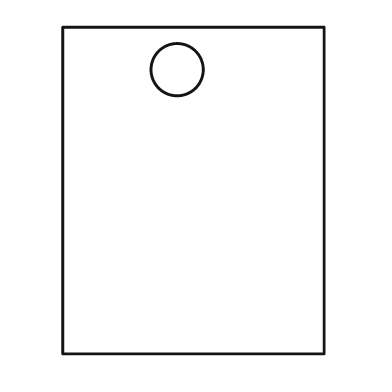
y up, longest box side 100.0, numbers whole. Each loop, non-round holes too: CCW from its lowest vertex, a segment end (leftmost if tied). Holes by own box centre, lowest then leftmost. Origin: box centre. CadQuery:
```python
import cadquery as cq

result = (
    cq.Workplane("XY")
    .moveTo(-40.0, -50.0)
    .lineTo(40.0, -50.0)
    .lineTo(40.0, 50.0)
    .lineTo(-40.0, 50.0)
    .close()
    .moveTo(-5.0, 37.0)
    .circle(8.0)
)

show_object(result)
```